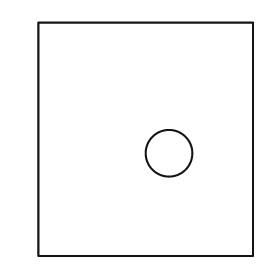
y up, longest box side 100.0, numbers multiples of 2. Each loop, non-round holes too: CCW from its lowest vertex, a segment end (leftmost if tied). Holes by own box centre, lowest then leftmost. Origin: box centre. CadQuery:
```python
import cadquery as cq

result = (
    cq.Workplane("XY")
    .moveTo(-46.0, -50.0)
    .lineTo(46.0, -50.0)
    .lineTo(46.0, 50.0)
    .lineTo(-46.0, 50.0)
    .close()
    .moveTo(10.0, -6.0)
    .circle(10.0)
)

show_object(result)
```